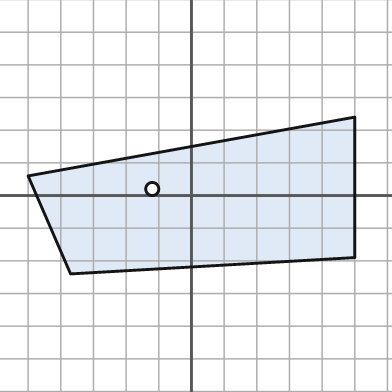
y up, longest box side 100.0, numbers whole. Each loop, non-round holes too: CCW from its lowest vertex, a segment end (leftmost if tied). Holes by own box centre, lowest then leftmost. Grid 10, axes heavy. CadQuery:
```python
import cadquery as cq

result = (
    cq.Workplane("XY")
    .moveTo(-37.0, -24.0)
    .lineTo(50.0, -19.0)
    .lineTo(50.0, 24.0)
    .lineTo(-50.0, 6.0)
    .close()
    .moveTo(-12.0, 2.0)
    .circle(2.0)
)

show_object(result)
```